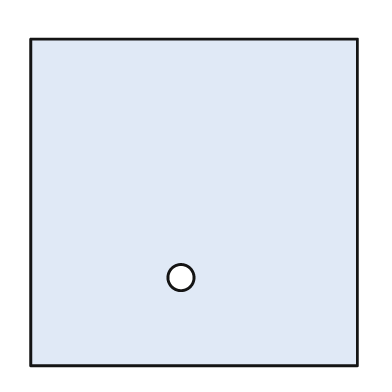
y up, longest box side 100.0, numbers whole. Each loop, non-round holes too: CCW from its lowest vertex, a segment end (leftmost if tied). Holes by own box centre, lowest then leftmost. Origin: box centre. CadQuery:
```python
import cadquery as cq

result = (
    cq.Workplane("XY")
    .moveTo(-50.0, -50.0)
    .lineTo(50.0, -50.0)
    .lineTo(50.0, 50.0)
    .lineTo(-50.0, 50.0)
    .close()
    .moveTo(-4.0, -23.0)
    .circle(4.0)
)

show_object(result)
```